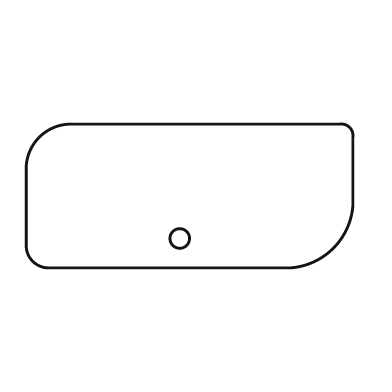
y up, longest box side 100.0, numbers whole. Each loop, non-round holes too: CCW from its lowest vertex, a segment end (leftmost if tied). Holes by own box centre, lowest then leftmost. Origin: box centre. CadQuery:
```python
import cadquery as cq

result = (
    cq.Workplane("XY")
    .moveTo(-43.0, -22.0)
    .lineTo(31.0, -22.0)
    .threePointArc((44.0, -16.0), (50.0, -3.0))
    .lineTo(50.0, 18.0)
    .threePointArc((49.0, 21.0), (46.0, 22.0))
    .lineTo(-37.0, 22.0)
    .threePointArc((-46.0, 18.0), (-50.0, 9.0))
    .lineTo(-50.0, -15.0)
    .threePointArc((-48.0, -20.0), (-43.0, -22.0))
    .close()
    .moveTo(-3.0, -13.0)
    .circle(3.0)
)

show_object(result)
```